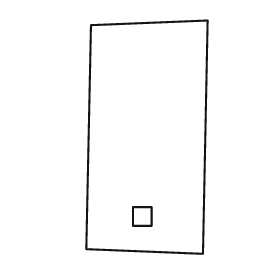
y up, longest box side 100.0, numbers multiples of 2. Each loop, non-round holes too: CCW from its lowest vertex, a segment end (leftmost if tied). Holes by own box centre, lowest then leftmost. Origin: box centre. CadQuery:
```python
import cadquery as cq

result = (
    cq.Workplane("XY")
    .moveTo(24.0, -50.0)
    .lineTo(26.0, 50.0)
    .lineTo(-24.0, 48.0)
    .lineTo(-26.0, -48.0)
    .close()
    .moveTo(-6.0, -38.0)
    .lineTo(2.0, -38.0)
    .lineTo(2.0, -30.0)
    .lineTo(-6.0, -30.0)
    .close()
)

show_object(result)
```